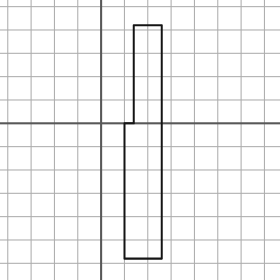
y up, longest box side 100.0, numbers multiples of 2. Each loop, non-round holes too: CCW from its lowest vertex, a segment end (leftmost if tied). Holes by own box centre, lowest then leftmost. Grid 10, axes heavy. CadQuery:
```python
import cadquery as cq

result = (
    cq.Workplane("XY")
    .moveTo(10.0, -58.0)
    .lineTo(26.0, -58.0)
    .lineTo(26.0, 42.0)
    .lineTo(14.0, 42.0)
    .lineTo(14.0, 0.0)
    .lineTo(10.0, 0.0)
    .close()
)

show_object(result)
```